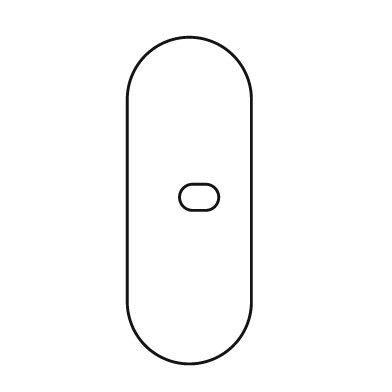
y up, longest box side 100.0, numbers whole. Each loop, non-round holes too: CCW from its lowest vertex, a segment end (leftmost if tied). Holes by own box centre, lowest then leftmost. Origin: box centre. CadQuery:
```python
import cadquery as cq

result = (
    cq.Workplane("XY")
    .moveTo(-19.0, -31.0)
    .threePointArc((0.0, -50.0), (19.0, -31.0))
    .lineTo(19.0, 31.0)
    .threePointArc((0.0, 50.0), (-19.0, 31.0))
    .close()
    .moveTo(1.0, -3.0)
    .lineTo(5.0, -3.0)
    .threePointArc((9.0, 1.0), (5.0, 5.0))
    .lineTo(1.0, 5.0)
    .threePointArc((-3.0, 1.0), (1.0, -3.0))
    .close()
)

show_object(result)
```